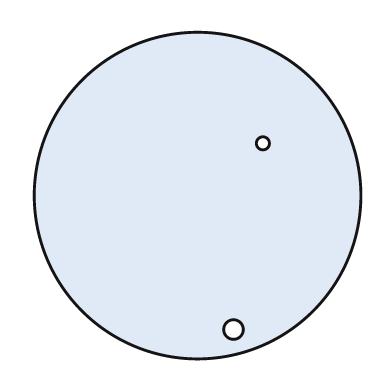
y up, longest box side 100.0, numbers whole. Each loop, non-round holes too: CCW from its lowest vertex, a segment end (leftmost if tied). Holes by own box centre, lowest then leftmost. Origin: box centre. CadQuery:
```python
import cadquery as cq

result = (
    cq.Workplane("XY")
    .moveTo(0.0, 0.0)
    .circle(50.0)
    .moveTo(11.0, -41.0)
    .circle(3.0)
    .moveTo(20.0, 16.0)
    .circle(2.0)
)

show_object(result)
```